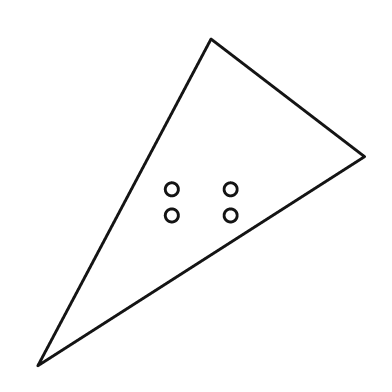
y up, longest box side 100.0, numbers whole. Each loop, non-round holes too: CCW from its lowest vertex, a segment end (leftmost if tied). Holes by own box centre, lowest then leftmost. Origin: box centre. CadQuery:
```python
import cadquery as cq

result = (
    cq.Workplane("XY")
    .moveTo(-50.0, -50.0)
    .lineTo(50.0, 14.0)
    .lineTo(3.0, 50.0)
    .close()
    .moveTo(-9.0, -4.0)
    .circle(2.0)
    .moveTo(9.0, -4.0)
    .circle(2.0)
    .moveTo(-9.0, 4.0)
    .circle(2.0)
    .moveTo(9.0, 4.0)
    .circle(2.0)
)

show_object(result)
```